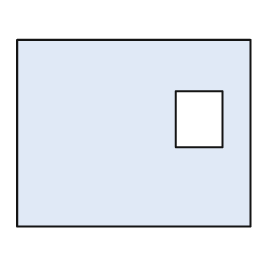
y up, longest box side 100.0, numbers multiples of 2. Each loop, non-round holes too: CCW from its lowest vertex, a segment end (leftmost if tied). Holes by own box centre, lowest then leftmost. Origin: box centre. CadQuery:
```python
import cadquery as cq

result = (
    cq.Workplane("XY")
    .moveTo(-50.0, -40.0)
    .lineTo(50.0, -40.0)
    .lineTo(50.0, 40.0)
    .lineTo(-50.0, 40.0)
    .close()
    .moveTo(18.0, -6.0)
    .lineTo(38.0, -6.0)
    .lineTo(38.0, 18.0)
    .lineTo(18.0, 18.0)
    .close()
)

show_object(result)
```